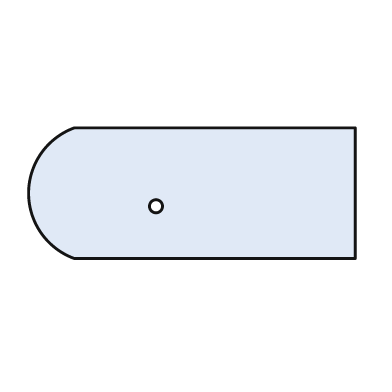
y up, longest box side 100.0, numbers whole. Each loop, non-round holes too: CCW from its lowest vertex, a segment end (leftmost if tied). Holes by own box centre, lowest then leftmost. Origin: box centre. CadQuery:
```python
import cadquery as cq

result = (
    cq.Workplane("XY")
    .moveTo(-36.0, -20.0)
    .lineTo(50.0, -20.0)
    .lineTo(50.0, 20.0)
    .lineTo(-36.0, 20.0)
    .threePointArc((-50.0, 0.0), (-36.0, -20.0))
    .close()
    .moveTo(-11.0, -4.0)
    .circle(2.0)
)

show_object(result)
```